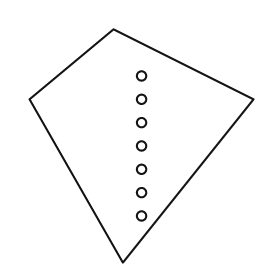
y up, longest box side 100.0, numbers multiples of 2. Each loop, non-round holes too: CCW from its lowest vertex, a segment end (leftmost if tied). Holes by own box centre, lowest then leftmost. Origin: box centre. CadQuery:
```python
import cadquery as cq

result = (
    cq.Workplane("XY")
    .moveTo(-8.0, -50.0)
    .lineTo(48.0, 20.0)
    .lineTo(-12.0, 50.0)
    .lineTo(-48.0, 20.0)
    .close()
    .moveTo(0.0, -30.0)
    .circle(2.0)
    .moveTo(0.0, -20.0)
    .circle(2.0)
    .moveTo(0.0, -10.0)
    .circle(2.0)
    .moveTo(0.0, 0.0)
    .circle(2.0)
    .moveTo(0.0, 10.0)
    .circle(2.0)
    .moveTo(0.0, 20.0)
    .circle(2.0)
    .moveTo(0.0, 30.0)
    .circle(2.0)
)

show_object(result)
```